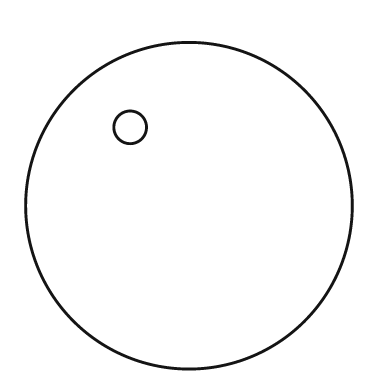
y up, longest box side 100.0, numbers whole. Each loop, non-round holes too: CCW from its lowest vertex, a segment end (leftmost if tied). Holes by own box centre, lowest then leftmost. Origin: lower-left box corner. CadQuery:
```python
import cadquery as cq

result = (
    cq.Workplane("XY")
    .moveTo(50.0, 50.0)
    .circle(50.0)
    .moveTo(32.0, 74.0)
    .circle(5.0)
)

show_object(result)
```